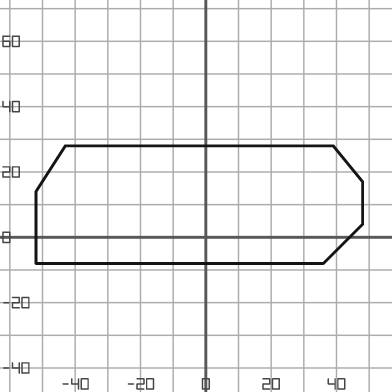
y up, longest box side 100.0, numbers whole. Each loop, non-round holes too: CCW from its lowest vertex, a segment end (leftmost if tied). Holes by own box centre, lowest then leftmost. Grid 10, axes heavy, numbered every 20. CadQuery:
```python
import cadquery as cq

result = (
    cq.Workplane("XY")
    .moveTo(-52.0, -8.0)
    .lineTo(36.0, -8.0)
    .lineTo(48.0, 4.0)
    .lineTo(48.0, 17.0)
    .lineTo(39.0, 28.0)
    .lineTo(-43.0, 28.0)
    .lineTo(-52.0, 14.0)
    .close()
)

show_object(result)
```